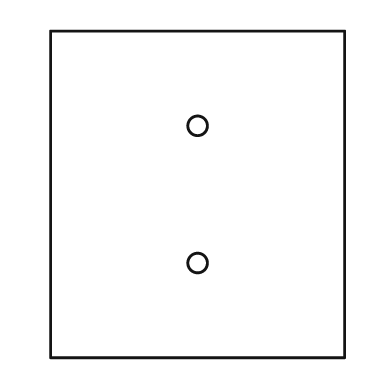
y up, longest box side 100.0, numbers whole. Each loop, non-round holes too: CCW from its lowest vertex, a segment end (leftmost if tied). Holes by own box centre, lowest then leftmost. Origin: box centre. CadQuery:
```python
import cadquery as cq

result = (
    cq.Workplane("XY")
    .moveTo(-45.0, -50.0)
    .lineTo(45.0, -50.0)
    .lineTo(45.0, 50.0)
    .lineTo(-45.0, 50.0)
    .close()
    .moveTo(0.0, -21.0)
    .circle(3.0)
    .moveTo(0.0, 21.0)
    .circle(3.0)
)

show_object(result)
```